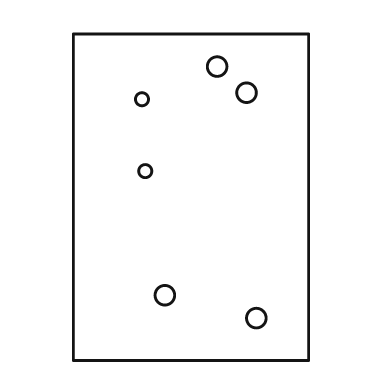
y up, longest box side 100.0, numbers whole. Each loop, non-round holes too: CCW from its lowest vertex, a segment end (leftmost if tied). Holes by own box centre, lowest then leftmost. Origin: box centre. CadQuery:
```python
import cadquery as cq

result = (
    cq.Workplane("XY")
    .moveTo(-36.0, -50.0)
    .lineTo(36.0, -50.0)
    .lineTo(36.0, 50.0)
    .lineTo(-36.0, 50.0)
    .close()
    .moveTo(20.0, -37.0)
    .circle(3.0)
    .moveTo(-8.0, -30.0)
    .circle(3.0)
    .moveTo(-14.0, 8.0)
    .circle(2.0)
    .moveTo(-15.0, 30.0)
    .circle(2.0)
    .moveTo(17.0, 32.0)
    .circle(3.0)
    .moveTo(8.0, 40.0)
    .circle(3.0)
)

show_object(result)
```